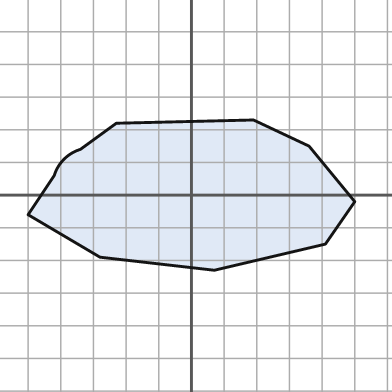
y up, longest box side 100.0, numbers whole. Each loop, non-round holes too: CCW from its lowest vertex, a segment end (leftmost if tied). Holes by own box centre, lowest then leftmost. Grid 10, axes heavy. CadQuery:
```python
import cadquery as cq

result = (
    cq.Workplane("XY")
    .moveTo(7.0, -23.0)
    .lineTo(41.0, -15.0)
    .lineTo(50.0, -2.0)
    .lineTo(36.0, 15.0)
    .lineTo(19.0, 23.0)
    .lineTo(-23.0, 22.0)
    .lineTo(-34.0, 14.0)
    .threePointArc((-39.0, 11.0), (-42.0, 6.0))
    .lineTo(-50.0, -6.0)
    .lineTo(-28.0, -19.0)
    .close()
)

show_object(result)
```